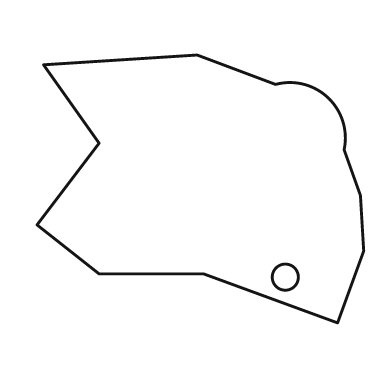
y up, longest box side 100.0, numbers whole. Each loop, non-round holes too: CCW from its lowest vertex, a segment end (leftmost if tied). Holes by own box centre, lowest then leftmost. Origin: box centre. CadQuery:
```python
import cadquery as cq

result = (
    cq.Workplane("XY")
    .moveTo(42.0, -41.0)
    .lineTo(50.0, -19.0)
    .lineTo(49.0, -2.0)
    .lineTo(44.0, 12.0)
    .threePointArc((39.0, 28.0), (23.0, 32.0))
    .lineTo(-1.0, 41.0)
    .lineTo(-48.0, 38.0)
    .lineTo(-31.0, 14.0)
    .lineTo(-50.0, -11.0)
    .lineTo(-31.0, -26.0)
    .lineTo(1.0, -26.0)
    .close()
    .moveTo(26.0, -27.0)
    .circle(4.0)
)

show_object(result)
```